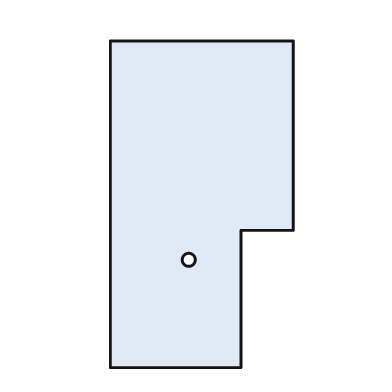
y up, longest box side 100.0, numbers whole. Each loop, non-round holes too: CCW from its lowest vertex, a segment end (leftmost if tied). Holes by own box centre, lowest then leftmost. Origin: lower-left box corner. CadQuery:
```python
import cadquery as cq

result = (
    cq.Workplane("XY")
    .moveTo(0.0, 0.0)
    .lineTo(40.0, 0.0)
    .lineTo(40.0, 42.0)
    .lineTo(56.0, 42.0)
    .lineTo(56.0, 100.0)
    .lineTo(0.0, 100.0)
    .close()
    .moveTo(24.0, 33.0)
    .circle(2.0)
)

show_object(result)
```